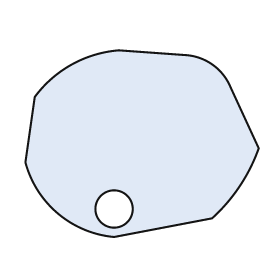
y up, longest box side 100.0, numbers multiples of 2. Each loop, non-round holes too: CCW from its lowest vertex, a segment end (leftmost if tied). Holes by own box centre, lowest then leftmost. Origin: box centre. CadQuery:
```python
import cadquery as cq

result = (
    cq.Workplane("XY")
    .moveTo(-12.0, -40.0)
    .lineTo(30.0, -32.0)
    .threePointArc((42.0, -18.0), (50.0, -2.0))
    .lineTo(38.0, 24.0)
    .threePointArc((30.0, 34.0), (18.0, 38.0))
    .lineTo(-10.0, 40.0)
    .threePointArc((-30.0, 34.0), (-46.0, 20.0))
    .lineTo(-50.0, -8.0)
    .threePointArc((-36.0, -30.0), (-12.0, -40.0))
    .close()
    .moveTo(-12.0, -28.0)
    .circle(8.0)
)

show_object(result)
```